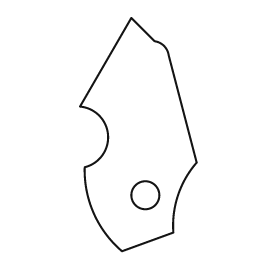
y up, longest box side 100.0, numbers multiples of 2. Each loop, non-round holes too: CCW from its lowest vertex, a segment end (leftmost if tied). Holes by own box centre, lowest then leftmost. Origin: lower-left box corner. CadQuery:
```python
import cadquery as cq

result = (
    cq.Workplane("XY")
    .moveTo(18.0, 0.0)
    .lineTo(40.0, 8.0)
    .threePointArc((42.0, 24.0), (50.0, 38.0))
    .lineTo(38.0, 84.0)
    .threePointArc((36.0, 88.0), (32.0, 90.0))
    .lineTo(22.0, 100.0)
    .lineTo(0.0, 62.0)
    .threePointArc((12.0, 50.0), (2.0, 36.0))
    .threePointArc((6.0, 16.0), (18.0, 0.0))
    .close()
    .moveTo(28.0, 24.0)
    .circle(6.0)
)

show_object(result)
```